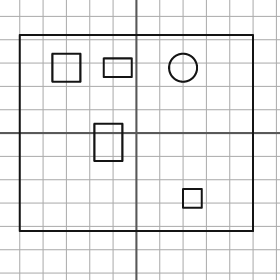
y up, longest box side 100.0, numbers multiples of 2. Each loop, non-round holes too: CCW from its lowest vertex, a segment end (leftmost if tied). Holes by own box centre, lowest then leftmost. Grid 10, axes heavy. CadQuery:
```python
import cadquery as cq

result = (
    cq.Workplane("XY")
    .moveTo(-50.0, -42.0)
    .lineTo(50.0, -42.0)
    .lineTo(50.0, 42.0)
    .lineTo(-50.0, 42.0)
    .close()
    .moveTo(20.0, -32.0)
    .lineTo(28.0, -32.0)
    .lineTo(28.0, -24.0)
    .lineTo(20.0, -24.0)
    .close()
    .moveTo(-18.0, -12.0)
    .lineTo(-6.0, -12.0)
    .lineTo(-6.0, 4.0)
    .lineTo(-18.0, 4.0)
    .close()
    .moveTo(-36.0, 22.0)
    .lineTo(-24.0, 22.0)
    .lineTo(-24.0, 34.0)
    .lineTo(-36.0, 34.0)
    .close()
    .moveTo(-14.0, 24.0)
    .lineTo(-2.0, 24.0)
    .lineTo(-2.0, 32.0)
    .lineTo(-14.0, 32.0)
    .close()
    .moveTo(20.0, 28.0)
    .circle(6.0)
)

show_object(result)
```